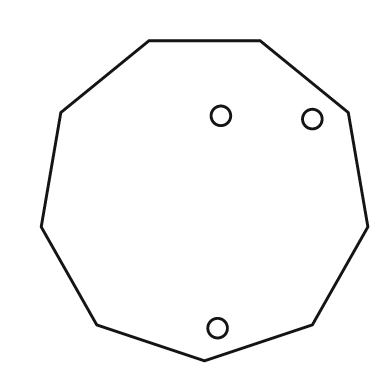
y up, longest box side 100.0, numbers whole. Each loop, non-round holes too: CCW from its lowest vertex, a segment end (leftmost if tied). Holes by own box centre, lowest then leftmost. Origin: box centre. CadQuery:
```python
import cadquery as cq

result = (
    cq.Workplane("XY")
    .moveTo(0.0, -49.0)
    .lineTo(33.0, -38.0)
    .lineTo(50.0, -8.0)
    .lineTo(44.0, 27.0)
    .lineTo(17.0, 49.0)
    .lineTo(-17.0, 49.0)
    .lineTo(-44.0, 27.0)
    .lineTo(-50.0, -8.0)
    .lineTo(-33.0, -38.0)
    .close()
    .moveTo(4.0, -39.0)
    .circle(3.0)
    .moveTo(33.0, 25.0)
    .circle(3.0)
    .moveTo(5.0, 26.0)
    .circle(3.0)
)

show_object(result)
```